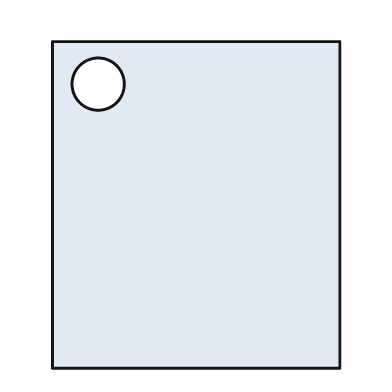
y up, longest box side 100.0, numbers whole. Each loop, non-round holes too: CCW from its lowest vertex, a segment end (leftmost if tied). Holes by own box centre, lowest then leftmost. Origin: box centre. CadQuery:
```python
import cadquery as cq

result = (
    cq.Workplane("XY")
    .moveTo(-44.0, -50.0)
    .lineTo(44.0, -50.0)
    .lineTo(44.0, 50.0)
    .lineTo(-44.0, 50.0)
    .close()
    .moveTo(-30.0, 37.0)
    .circle(8.0)
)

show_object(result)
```